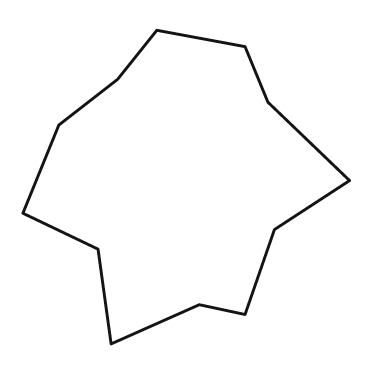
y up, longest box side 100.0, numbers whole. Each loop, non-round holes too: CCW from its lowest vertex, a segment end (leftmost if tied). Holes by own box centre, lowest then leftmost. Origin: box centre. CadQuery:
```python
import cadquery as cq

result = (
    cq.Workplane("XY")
    .moveTo(-23.0, -48.0)
    .lineTo(4.0, -36.0)
    .lineTo(18.0, -39.0)
    .lineTo(27.0, -13.0)
    .lineTo(50.0, 2.0)
    .lineTo(25.0, 26.0)
    .lineTo(18.0, 43.0)
    .lineTo(-9.0, 48.0)
    .lineTo(-21.0, 33.0)
    .lineTo(-39.0, 19.0)
    .lineTo(-50.0, -8.0)
    .lineTo(-27.0, -19.0)
    .close()
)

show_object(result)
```